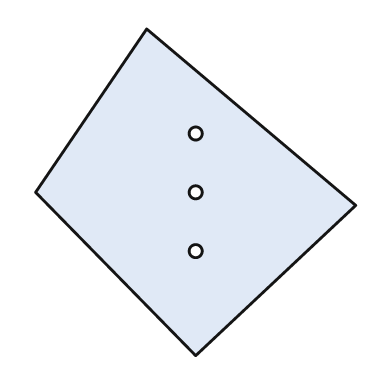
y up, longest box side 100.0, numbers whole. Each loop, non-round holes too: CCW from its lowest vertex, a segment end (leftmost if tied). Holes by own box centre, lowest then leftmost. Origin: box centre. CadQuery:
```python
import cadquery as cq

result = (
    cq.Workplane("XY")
    .moveTo(0.0, -50.0)
    .lineTo(49.0, -4.0)
    .lineTo(-15.0, 50.0)
    .lineTo(-49.0, 0.0)
    .close()
    .moveTo(0.0, -18.0)
    .circle(2.0)
    .moveTo(0.0, 0.0)
    .circle(2.0)
    .moveTo(0.0, 18.0)
    .circle(2.0)
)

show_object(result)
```